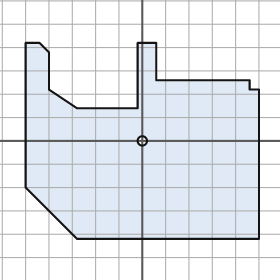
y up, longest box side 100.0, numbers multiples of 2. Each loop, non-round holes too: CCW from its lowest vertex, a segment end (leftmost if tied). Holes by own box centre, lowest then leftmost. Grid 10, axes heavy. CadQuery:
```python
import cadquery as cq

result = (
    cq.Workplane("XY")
    .moveTo(-28.0, -42.0)
    .lineTo(50.0, -42.0)
    .lineTo(50.0, 22.0)
    .lineTo(46.0, 22.0)
    .lineTo(46.0, 26.0)
    .lineTo(6.0, 26.0)
    .lineTo(6.0, 42.0)
    .lineTo(-2.0, 42.0)
    .lineTo(-2.0, 14.0)
    .lineTo(-28.0, 14.0)
    .lineTo(-40.0, 22.0)
    .lineTo(-40.0, 38.0)
    .lineTo(-44.0, 42.0)
    .lineTo(-50.0, 42.0)
    .lineTo(-50.0, -20.0)
    .close()
    .moveTo(0.0, 0.0)
    .circle(2.0)
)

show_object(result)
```